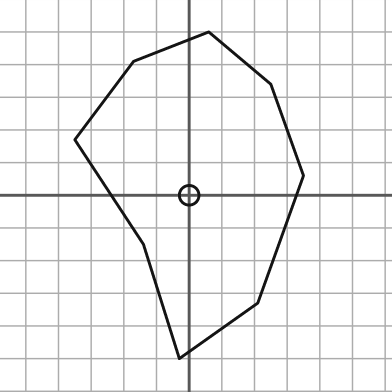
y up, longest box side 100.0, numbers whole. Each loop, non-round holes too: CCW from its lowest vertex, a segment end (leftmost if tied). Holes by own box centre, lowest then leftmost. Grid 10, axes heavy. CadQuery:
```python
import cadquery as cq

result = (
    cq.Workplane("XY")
    .moveTo(-3.0, -50.0)
    .lineTo(21.0, -33.0)
    .lineTo(35.0, 6.0)
    .lineTo(25.0, 34.0)
    .lineTo(6.0, 50.0)
    .lineTo(-17.0, 41.0)
    .lineTo(-35.0, 17.0)
    .lineTo(-14.0, -15.0)
    .close()
    .moveTo(0.0, 0.0)
    .circle(3.0)
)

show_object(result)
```